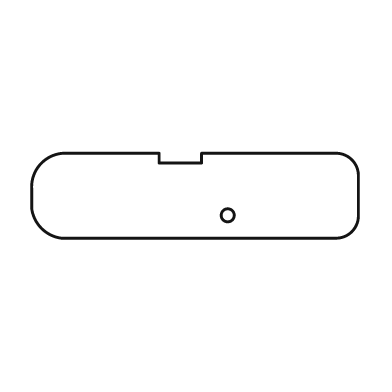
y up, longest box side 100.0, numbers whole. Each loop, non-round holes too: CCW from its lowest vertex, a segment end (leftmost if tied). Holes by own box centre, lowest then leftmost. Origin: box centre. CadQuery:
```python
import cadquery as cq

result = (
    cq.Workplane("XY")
    .moveTo(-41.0, -13.0)
    .lineTo(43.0, -13.0)
    .threePointArc((48.0, -11.0), (50.0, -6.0))
    .lineTo(50.0, 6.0)
    .threePointArc((48.0, 11.0), (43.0, 13.0))
    .lineTo(2.0, 13.0)
    .lineTo(2.0, 10.0)
    .lineTo(-11.0, 10.0)
    .lineTo(-11.0, 13.0)
    .lineTo(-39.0, 13.0)
    .threePointArc((-47.0, 10.0), (-50.0, 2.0))
    .lineTo(-50.0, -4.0)
    .threePointArc((-47.0, -10.0), (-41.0, -13.0))
    .close()
    .moveTo(10.0, -6.0)
    .circle(2.0)
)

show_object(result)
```